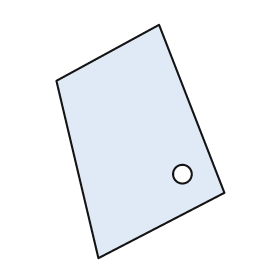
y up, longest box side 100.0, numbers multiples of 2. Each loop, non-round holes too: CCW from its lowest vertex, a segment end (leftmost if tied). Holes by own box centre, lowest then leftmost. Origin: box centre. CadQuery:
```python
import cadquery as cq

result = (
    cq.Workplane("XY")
    .moveTo(-18.0, -50.0)
    .lineTo(36.0, -22.0)
    .lineTo(8.0, 50.0)
    .lineTo(-36.0, 26.0)
    .close()
    .moveTo(18.0, -14.0)
    .circle(4.0)
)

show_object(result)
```